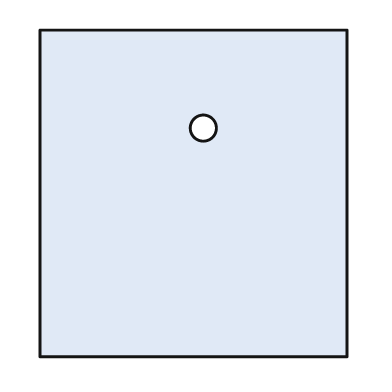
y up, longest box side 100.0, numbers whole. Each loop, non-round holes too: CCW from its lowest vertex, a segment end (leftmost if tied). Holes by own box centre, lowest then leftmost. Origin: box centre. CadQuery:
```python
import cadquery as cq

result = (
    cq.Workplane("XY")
    .moveTo(-47.0, -50.0)
    .lineTo(47.0, -50.0)
    .lineTo(47.0, 50.0)
    .lineTo(-47.0, 50.0)
    .close()
    .moveTo(3.0, 20.0)
    .circle(4.0)
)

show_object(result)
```